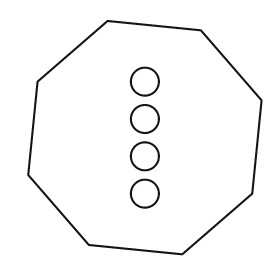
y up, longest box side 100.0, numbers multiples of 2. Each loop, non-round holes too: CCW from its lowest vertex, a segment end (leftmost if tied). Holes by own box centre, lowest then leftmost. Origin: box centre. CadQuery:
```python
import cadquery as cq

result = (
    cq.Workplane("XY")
    .moveTo(16.0, -50.0)
    .lineTo(46.0, -24.0)
    .lineTo(50.0, 16.0)
    .lineTo(24.0, 46.0)
    .lineTo(-16.0, 50.0)
    .lineTo(-46.0, 24.0)
    .lineTo(-50.0, -16.0)
    .lineTo(-24.0, -46.0)
    .close()
    .moveTo(0.0, -24.0)
    .circle(6.0)
    .moveTo(0.0, -8.0)
    .circle(6.0)
    .moveTo(0.0, 8.0)
    .circle(6.0)
    .moveTo(0.0, 24.0)
    .circle(6.0)
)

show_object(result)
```